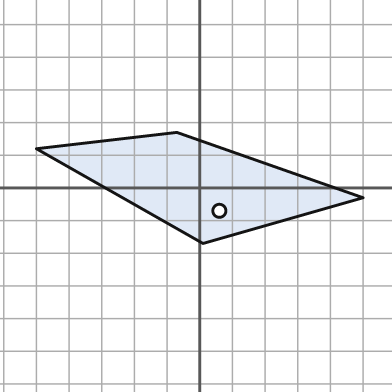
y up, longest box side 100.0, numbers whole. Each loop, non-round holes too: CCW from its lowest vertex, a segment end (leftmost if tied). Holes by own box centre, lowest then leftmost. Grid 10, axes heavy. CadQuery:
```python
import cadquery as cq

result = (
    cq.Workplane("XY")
    .moveTo(1.0, -17.0)
    .lineTo(50.0, -3.0)
    .lineTo(-7.0, 17.0)
    .lineTo(-50.0, 12.0)
    .close()
    .moveTo(6.0, -7.0)
    .circle(2.0)
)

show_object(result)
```